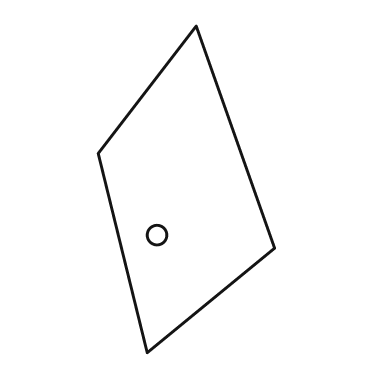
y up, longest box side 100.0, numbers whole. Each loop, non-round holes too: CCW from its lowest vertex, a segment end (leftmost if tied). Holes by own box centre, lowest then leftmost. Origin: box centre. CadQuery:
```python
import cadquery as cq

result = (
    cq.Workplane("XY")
    .moveTo(-12.0, -50.0)
    .lineTo(27.0, -18.0)
    .lineTo(3.0, 50.0)
    .lineTo(-27.0, 11.0)
    .close()
    .moveTo(-9.0, -14.0)
    .circle(3.0)
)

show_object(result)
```